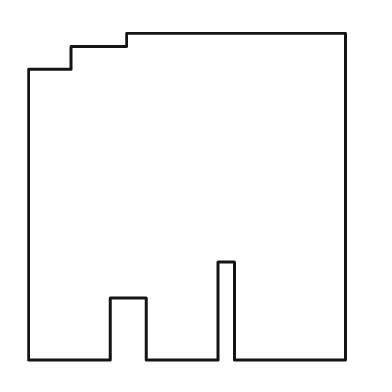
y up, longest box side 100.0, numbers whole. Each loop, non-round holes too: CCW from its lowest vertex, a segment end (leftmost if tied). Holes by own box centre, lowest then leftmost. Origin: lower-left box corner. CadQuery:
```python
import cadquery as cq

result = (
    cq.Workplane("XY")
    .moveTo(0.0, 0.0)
    .lineTo(25.0, 0.0)
    .lineTo(25.0, 19.0)
    .lineTo(36.0, 19.0)
    .lineTo(36.0, 0.0)
    .lineTo(58.0, 0.0)
    .lineTo(58.0, 30.0)
    .lineTo(63.0, 30.0)
    .lineTo(63.0, 0.0)
    .lineTo(97.0, 0.0)
    .lineTo(97.0, 100.0)
    .lineTo(30.0, 100.0)
    .lineTo(30.0, 96.0)
    .lineTo(13.0, 96.0)
    .lineTo(13.0, 89.0)
    .lineTo(0.0, 89.0)
    .close()
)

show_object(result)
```